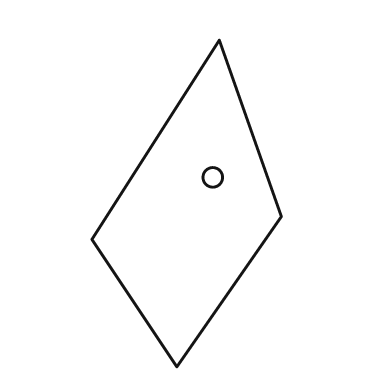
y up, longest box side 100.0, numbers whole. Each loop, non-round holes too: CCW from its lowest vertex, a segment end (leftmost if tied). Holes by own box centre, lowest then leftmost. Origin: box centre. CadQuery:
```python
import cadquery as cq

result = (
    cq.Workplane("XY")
    .moveTo(-3.0, -50.0)
    .lineTo(29.0, -4.0)
    .lineTo(10.0, 50.0)
    .lineTo(-29.0, -11.0)
    .close()
    .moveTo(8.0, 8.0)
    .circle(3.0)
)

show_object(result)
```